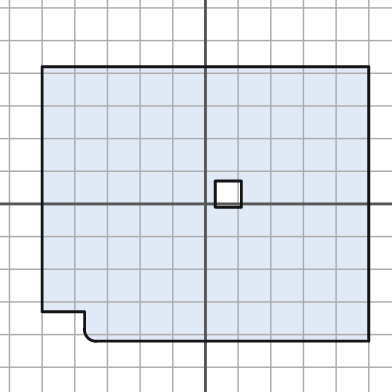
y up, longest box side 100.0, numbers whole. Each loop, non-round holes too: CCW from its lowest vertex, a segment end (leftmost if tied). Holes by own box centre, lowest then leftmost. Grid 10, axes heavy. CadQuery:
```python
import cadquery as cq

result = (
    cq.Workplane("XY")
    .moveTo(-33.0, -42.0)
    .lineTo(50.0, -42.0)
    .lineTo(50.0, 42.0)
    .lineTo(-50.0, 42.0)
    .lineTo(-50.0, -33.0)
    .lineTo(-37.0, -33.0)
    .lineTo(-37.0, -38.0)
    .threePointArc((-36.0, -41.0), (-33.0, -42.0))
    .close()
    .moveTo(3.0, -1.0)
    .lineTo(11.0, -1.0)
    .lineTo(11.0, 7.0)
    .lineTo(3.0, 7.0)
    .close()
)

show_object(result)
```